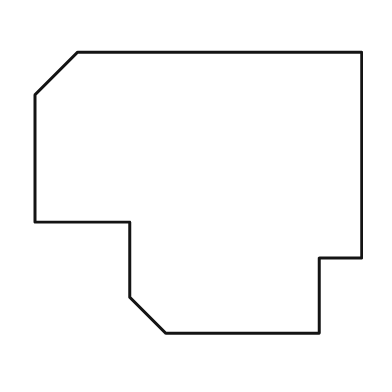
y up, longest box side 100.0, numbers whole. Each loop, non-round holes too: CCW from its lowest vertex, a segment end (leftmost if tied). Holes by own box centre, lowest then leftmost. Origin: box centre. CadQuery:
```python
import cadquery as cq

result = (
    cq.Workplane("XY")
    .moveTo(-10.0, -43.0)
    .lineTo(37.0, -43.0)
    .lineTo(37.0, -20.0)
    .lineTo(50.0, -20.0)
    .lineTo(50.0, 43.0)
    .lineTo(-37.0, 43.0)
    .lineTo(-50.0, 30.0)
    .lineTo(-50.0, -9.0)
    .lineTo(-21.0, -9.0)
    .lineTo(-21.0, -32.0)
    .close()
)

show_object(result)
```